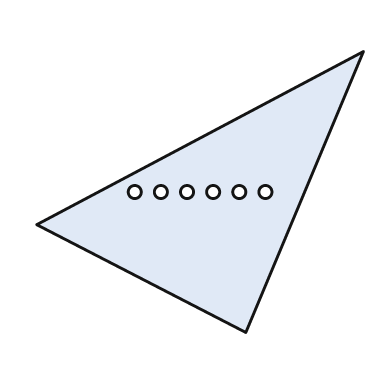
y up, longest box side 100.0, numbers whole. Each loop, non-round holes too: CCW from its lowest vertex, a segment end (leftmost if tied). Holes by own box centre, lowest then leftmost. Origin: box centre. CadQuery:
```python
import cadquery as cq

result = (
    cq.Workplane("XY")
    .moveTo(14.0, -43.0)
    .lineTo(50.0, 43.0)
    .lineTo(-50.0, -10.0)
    .close()
    .moveTo(-20.0, 0.0)
    .circle(2.0)
    .moveTo(-12.0, 0.0)
    .circle(2.0)
    .moveTo(-4.0, 0.0)
    .circle(2.0)
    .moveTo(4.0, 0.0)
    .circle(2.0)
    .moveTo(12.0, 0.0)
    .circle(2.0)
    .moveTo(20.0, 0.0)
    .circle(2.0)
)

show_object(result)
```